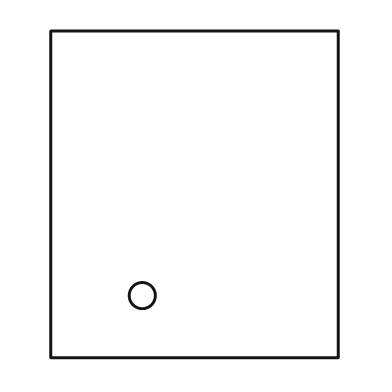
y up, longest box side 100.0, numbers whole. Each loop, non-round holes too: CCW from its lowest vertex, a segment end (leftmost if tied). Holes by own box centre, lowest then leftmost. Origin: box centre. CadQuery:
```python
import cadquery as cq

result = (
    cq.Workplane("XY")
    .moveTo(-44.0, -50.0)
    .lineTo(44.0, -50.0)
    .lineTo(44.0, 50.0)
    .lineTo(-44.0, 50.0)
    .close()
    .moveTo(-16.0, -31.0)
    .circle(4.0)
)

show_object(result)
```